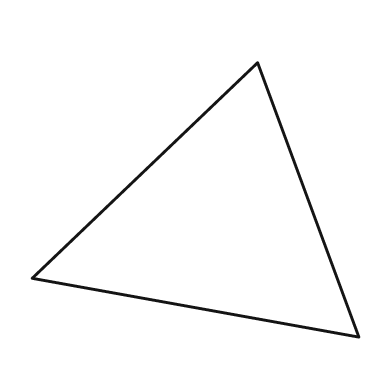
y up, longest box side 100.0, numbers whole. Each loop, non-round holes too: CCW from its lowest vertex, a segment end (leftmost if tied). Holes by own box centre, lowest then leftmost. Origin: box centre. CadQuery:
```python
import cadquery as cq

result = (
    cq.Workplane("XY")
    .moveTo(50.0, -42.0)
    .lineTo(19.0, 42.0)
    .lineTo(-50.0, -24.0)
    .close()
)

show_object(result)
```